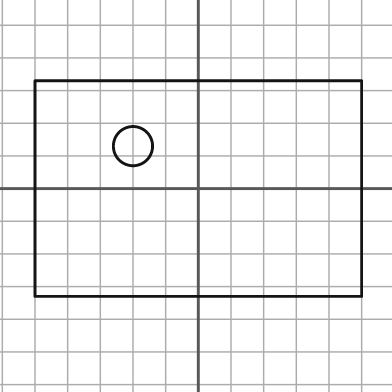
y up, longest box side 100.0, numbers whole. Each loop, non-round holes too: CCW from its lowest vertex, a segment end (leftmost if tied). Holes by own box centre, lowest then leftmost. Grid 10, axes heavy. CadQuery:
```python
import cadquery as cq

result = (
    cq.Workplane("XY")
    .moveTo(-50.0, -33.0)
    .lineTo(50.0, -33.0)
    .lineTo(50.0, 33.0)
    .lineTo(-50.0, 33.0)
    .close()
    .moveTo(-20.0, 13.0)
    .circle(6.0)
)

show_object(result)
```